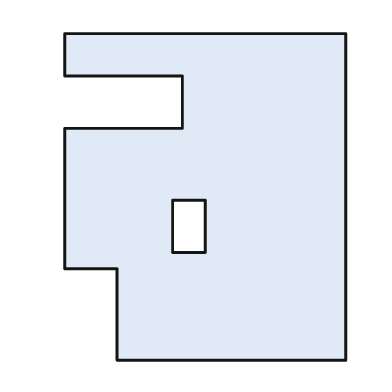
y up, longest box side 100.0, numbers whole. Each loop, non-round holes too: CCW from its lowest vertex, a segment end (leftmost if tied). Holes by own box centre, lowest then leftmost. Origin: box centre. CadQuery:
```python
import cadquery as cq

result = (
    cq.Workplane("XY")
    .moveTo(-27.0, -50.0)
    .lineTo(43.0, -50.0)
    .lineTo(43.0, 50.0)
    .lineTo(-43.0, 50.0)
    .lineTo(-43.0, 37.0)
    .lineTo(-7.0, 37.0)
    .lineTo(-7.0, 21.0)
    .lineTo(-43.0, 21.0)
    .lineTo(-43.0, -22.0)
    .lineTo(-27.0, -22.0)
    .close()
    .moveTo(-10.0, -17.0)
    .lineTo(0.0, -17.0)
    .lineTo(0.0, -1.0)
    .lineTo(-10.0, -1.0)
    .close()
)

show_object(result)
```